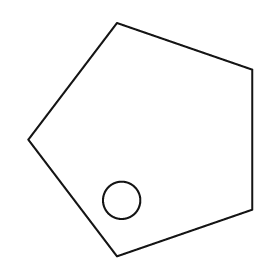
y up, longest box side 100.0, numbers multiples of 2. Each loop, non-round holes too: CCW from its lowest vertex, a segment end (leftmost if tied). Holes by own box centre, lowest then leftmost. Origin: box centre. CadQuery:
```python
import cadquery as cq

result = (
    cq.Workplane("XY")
    .moveTo(-10.0, -50.0)
    .lineTo(48.0, -30.0)
    .lineTo(48.0, 30.0)
    .lineTo(-10.0, 50.0)
    .lineTo(-48.0, 0.0)
    .close()
    .moveTo(-8.0, -26.0)
    .circle(8.0)
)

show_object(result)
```